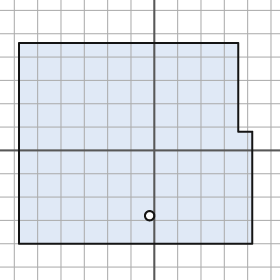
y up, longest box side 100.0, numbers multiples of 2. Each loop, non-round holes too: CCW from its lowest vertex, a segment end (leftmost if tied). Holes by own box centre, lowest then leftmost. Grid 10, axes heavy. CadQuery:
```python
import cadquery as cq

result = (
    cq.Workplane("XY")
    .moveTo(-58.0, -40.0)
    .lineTo(42.0, -40.0)
    .lineTo(42.0, 8.0)
    .lineTo(36.0, 8.0)
    .lineTo(36.0, 46.0)
    .lineTo(-58.0, 46.0)
    .close()
    .moveTo(-2.0, -28.0)
    .circle(2.0)
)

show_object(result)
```